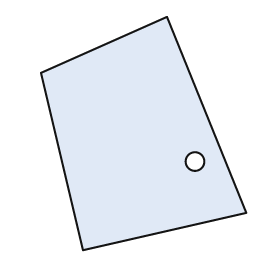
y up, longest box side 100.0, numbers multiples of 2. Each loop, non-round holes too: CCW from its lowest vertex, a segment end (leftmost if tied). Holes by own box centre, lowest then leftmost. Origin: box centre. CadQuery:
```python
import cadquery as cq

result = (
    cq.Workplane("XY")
    .moveTo(-26.0, -50.0)
    .lineTo(44.0, -34.0)
    .lineTo(10.0, 50.0)
    .lineTo(-44.0, 26.0)
    .close()
    .moveTo(22.0, -12.0)
    .circle(4.0)
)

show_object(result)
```